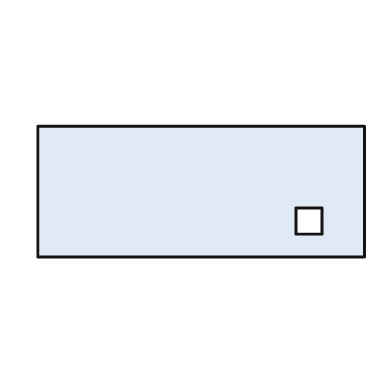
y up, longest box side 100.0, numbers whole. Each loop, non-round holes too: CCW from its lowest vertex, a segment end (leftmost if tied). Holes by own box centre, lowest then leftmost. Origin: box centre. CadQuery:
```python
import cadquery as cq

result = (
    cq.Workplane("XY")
    .moveTo(-50.0, -20.0)
    .lineTo(50.0, -20.0)
    .lineTo(50.0, 20.0)
    .lineTo(-50.0, 20.0)
    .close()
    .moveTo(29.0, -13.0)
    .lineTo(37.0, -13.0)
    .lineTo(37.0, -5.0)
    .lineTo(29.0, -5.0)
    .close()
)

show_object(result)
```